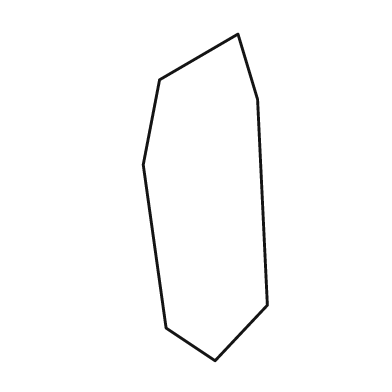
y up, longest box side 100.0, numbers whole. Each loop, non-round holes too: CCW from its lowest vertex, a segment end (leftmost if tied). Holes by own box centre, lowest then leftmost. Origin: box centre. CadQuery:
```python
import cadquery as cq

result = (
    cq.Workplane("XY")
    .moveTo(3.0, -50.0)
    .lineTo(19.0, -33.0)
    .lineTo(16.0, 30.0)
    .lineTo(10.0, 50.0)
    .lineTo(-14.0, 36.0)
    .lineTo(-19.0, 10.0)
    .lineTo(-12.0, -40.0)
    .close()
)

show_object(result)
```